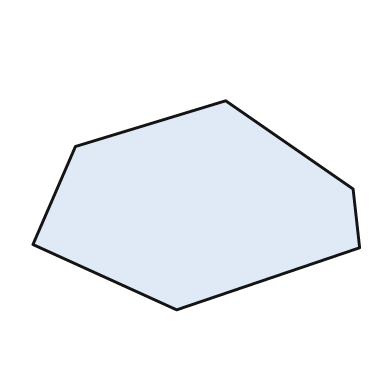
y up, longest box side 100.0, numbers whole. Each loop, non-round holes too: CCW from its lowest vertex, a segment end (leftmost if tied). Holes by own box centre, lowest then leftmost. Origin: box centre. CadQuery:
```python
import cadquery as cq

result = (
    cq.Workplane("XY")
    .moveTo(-6.0, -32.0)
    .lineTo(50.0, -13.0)
    .lineTo(48.0, 5.0)
    .lineTo(9.0, 32.0)
    .lineTo(-37.0, 18.0)
    .lineTo(-50.0, -12.0)
    .close()
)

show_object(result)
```